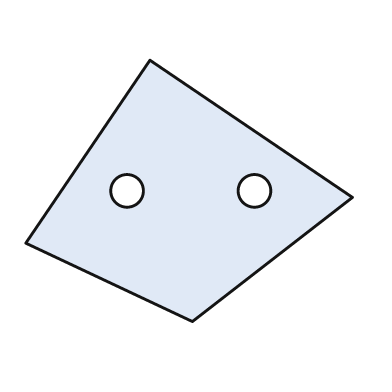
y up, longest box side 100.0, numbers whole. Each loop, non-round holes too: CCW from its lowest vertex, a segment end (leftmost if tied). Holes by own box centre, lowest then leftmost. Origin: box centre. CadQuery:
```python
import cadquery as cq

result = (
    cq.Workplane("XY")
    .moveTo(1.0, -40.0)
    .lineTo(50.0, -2.0)
    .lineTo(-12.0, 40.0)
    .lineTo(-50.0, -16.0)
    .close()
    .moveTo(-19.0, 0.0)
    .circle(5.0)
    .moveTo(20.0, 0.0)
    .circle(5.0)
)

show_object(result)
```